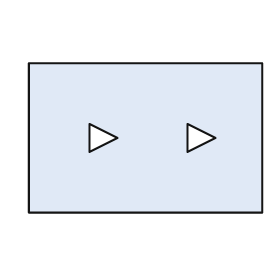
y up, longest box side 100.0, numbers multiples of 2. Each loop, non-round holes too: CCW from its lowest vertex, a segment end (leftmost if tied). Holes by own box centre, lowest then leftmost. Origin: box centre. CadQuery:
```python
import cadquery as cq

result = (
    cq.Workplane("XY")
    .moveTo(-50.0, -32.0)
    .lineTo(50.0, -32.0)
    .lineTo(50.0, 32.0)
    .lineTo(-50.0, 32.0)
    .close()
    .moveTo(-24.0, -6.0)
    .lineTo(-12.0, 0.0)
    .lineTo(-24.0, 6.0)
    .close()
    .moveTo(18.0, -6.0)
    .lineTo(30.0, 0.0)
    .lineTo(18.0, 6.0)
    .close()
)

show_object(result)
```